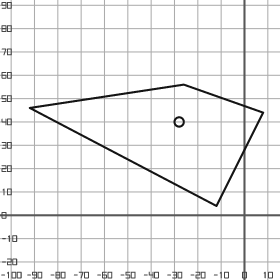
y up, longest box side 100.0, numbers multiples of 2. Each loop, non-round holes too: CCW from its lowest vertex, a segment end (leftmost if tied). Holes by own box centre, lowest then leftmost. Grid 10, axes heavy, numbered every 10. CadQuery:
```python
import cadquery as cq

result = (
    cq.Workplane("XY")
    .moveTo(-12.0, 4.0)
    .lineTo(8.0, 44.0)
    .lineTo(-26.0, 56.0)
    .lineTo(-92.0, 46.0)
    .close()
    .moveTo(-28.0, 40.0)
    .circle(2.0)
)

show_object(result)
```